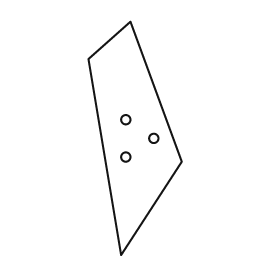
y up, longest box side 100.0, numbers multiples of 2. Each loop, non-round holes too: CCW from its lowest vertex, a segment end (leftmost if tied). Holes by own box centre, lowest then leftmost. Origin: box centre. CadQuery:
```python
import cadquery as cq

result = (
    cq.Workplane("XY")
    .moveTo(-6.0, -50.0)
    .lineTo(20.0, -10.0)
    .lineTo(-2.0, 50.0)
    .lineTo(-20.0, 34.0)
    .close()
    .moveTo(-4.0, -8.0)
    .circle(2.0)
    .moveTo(8.0, 0.0)
    .circle(2.0)
    .moveTo(-4.0, 8.0)
    .circle(2.0)
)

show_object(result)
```